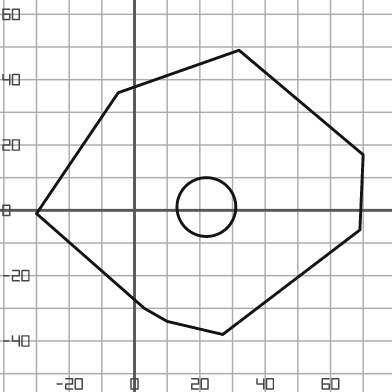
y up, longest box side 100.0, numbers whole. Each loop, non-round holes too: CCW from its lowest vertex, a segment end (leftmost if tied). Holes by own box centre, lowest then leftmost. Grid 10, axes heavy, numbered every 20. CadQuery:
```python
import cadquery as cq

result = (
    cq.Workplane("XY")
    .moveTo(27.0, -38.0)
    .lineTo(69.0, -6.0)
    .lineTo(70.0, 17.0)
    .lineTo(32.0, 49.0)
    .lineTo(-5.0, 36.0)
    .lineTo(-30.0, -1.0)
    .lineTo(3.0, -30.0)
    .lineTo(10.0, -34.0)
    .close()
    .moveTo(22.0, 1.0)
    .circle(9.0)
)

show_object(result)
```